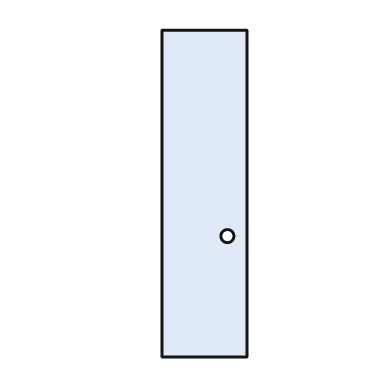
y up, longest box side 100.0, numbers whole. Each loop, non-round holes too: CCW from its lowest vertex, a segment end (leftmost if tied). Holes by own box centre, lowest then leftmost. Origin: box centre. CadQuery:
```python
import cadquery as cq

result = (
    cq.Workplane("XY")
    .moveTo(-13.0, -50.0)
    .lineTo(13.0, -50.0)
    .lineTo(13.0, 50.0)
    .lineTo(-13.0, 50.0)
    .close()
    .moveTo(7.0, -13.0)
    .circle(2.0)
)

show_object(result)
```